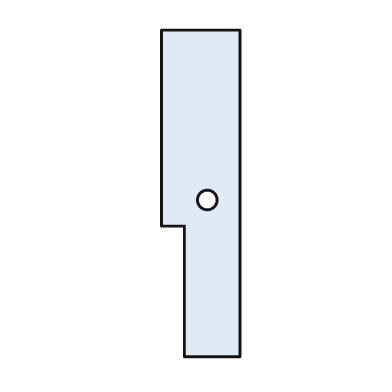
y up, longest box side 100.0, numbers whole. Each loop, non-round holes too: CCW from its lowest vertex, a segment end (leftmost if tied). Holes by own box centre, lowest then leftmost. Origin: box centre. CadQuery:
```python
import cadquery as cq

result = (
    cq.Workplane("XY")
    .moveTo(-5.0, -50.0)
    .lineTo(12.0, -50.0)
    .lineTo(12.0, 50.0)
    .lineTo(-12.0, 50.0)
    .lineTo(-12.0, -10.0)
    .lineTo(-5.0, -10.0)
    .close()
    .moveTo(2.0, -2.0)
    .circle(3.0)
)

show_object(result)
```